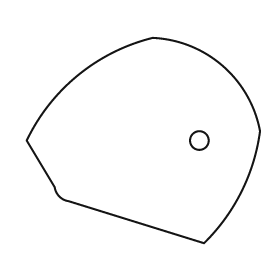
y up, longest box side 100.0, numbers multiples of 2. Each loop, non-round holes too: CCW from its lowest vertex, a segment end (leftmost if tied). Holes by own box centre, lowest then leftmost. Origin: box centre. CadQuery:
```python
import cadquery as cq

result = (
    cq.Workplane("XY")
    .moveTo(26.0, -44.0)
    .threePointArc((42.0, -22.0), (50.0, 4.0))
    .threePointArc((34.0, 32.0), (4.0, 44.0))
    .threePointArc((-28.0, 28.0), (-50.0, 0.0))
    .lineTo(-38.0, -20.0)
    .threePointArc((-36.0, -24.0), (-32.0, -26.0))
    .close()
    .moveTo(24.0, 0.0)
    .circle(4.0)
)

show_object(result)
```